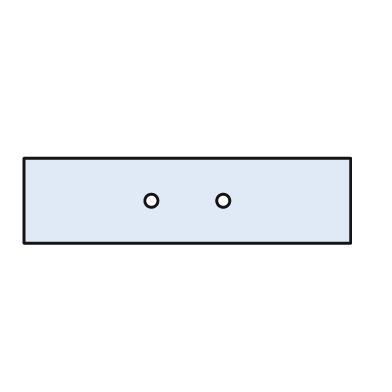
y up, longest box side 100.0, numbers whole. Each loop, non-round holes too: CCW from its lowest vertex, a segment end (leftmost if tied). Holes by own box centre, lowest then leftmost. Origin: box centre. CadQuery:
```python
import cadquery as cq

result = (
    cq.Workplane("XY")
    .moveTo(-50.0, -13.0)
    .lineTo(50.0, -13.0)
    .lineTo(50.0, 13.0)
    .lineTo(-50.0, 13.0)
    .close()
    .moveTo(-11.0, 0.0)
    .circle(2.0)
    .moveTo(11.0, 0.0)
    .circle(2.0)
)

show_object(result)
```